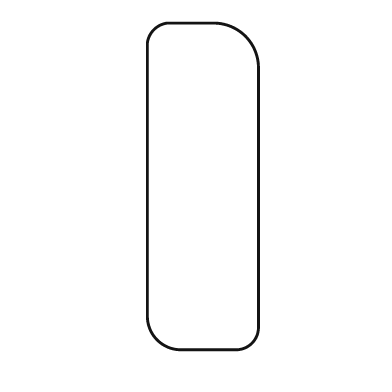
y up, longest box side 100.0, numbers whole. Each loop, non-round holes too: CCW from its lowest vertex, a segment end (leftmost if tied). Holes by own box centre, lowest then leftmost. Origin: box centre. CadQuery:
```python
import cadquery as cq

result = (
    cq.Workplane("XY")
    .moveTo(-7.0, -50.0)
    .lineTo(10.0, -50.0)
    .threePointArc((15.0, -48.0), (17.0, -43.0))
    .lineTo(17.0, 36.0)
    .threePointArc((13.0, 46.0), (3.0, 50.0))
    .lineTo(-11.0, 50.0)
    .threePointArc((-15.0, 48.0), (-17.0, 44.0))
    .lineTo(-17.0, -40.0)
    .threePointArc((-14.0, -47.0), (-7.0, -50.0))
    .close()
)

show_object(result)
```